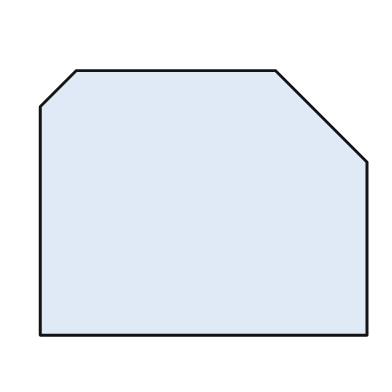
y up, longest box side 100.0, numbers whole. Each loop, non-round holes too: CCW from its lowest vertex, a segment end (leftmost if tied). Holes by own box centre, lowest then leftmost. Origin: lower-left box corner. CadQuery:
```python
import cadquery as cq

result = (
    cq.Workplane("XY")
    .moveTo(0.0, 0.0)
    .lineTo(100.0, 0.0)
    .lineTo(100.0, 53.0)
    .lineTo(72.0, 81.0)
    .lineTo(11.0, 81.0)
    .lineTo(0.0, 70.0)
    .close()
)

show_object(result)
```